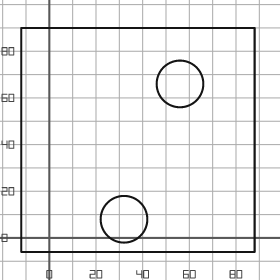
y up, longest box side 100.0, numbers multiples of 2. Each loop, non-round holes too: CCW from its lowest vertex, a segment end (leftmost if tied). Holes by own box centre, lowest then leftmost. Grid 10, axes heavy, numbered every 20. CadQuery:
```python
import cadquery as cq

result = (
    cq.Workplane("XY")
    .moveTo(-12.0, -6.0)
    .lineTo(88.0, -6.0)
    .lineTo(88.0, 90.0)
    .lineTo(-12.0, 90.0)
    .close()
    .moveTo(32.0, 8.0)
    .circle(10.0)
    .moveTo(56.0, 66.0)
    .circle(10.0)
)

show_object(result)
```